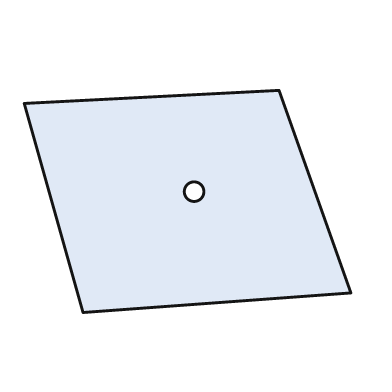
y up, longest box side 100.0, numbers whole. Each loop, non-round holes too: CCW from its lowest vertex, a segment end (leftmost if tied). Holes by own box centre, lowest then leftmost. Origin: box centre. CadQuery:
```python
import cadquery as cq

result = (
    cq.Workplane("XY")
    .moveTo(-32.0, -34.0)
    .lineTo(50.0, -28.0)
    .lineTo(28.0, 34.0)
    .lineTo(-50.0, 30.0)
    .close()
    .moveTo(2.0, 3.0)
    .circle(3.0)
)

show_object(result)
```